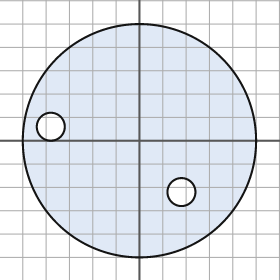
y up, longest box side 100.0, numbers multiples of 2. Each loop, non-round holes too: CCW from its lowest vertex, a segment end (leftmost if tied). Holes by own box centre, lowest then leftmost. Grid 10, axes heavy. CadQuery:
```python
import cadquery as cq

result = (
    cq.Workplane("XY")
    .moveTo(0.0, 0.0)
    .circle(50.0)
    .moveTo(18.0, -22.0)
    .circle(6.0)
    .moveTo(-38.0, 6.0)
    .circle(6.0)
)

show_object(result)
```